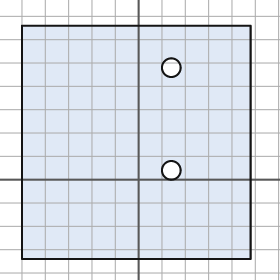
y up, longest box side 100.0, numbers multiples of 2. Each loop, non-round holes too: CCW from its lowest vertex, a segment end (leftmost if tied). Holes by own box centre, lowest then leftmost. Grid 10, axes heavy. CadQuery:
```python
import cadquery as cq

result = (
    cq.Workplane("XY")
    .moveTo(-50.0, -34.0)
    .lineTo(48.0, -34.0)
    .lineTo(48.0, 66.0)
    .lineTo(-50.0, 66.0)
    .close()
    .moveTo(14.0, 4.0)
    .circle(4.0)
    .moveTo(14.0, 48.0)
    .circle(4.0)
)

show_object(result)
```